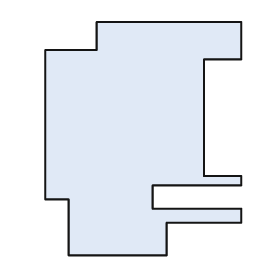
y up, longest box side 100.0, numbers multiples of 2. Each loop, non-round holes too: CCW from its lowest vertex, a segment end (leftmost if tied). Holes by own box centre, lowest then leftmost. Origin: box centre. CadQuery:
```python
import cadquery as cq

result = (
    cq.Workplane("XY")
    .moveTo(-32.0, -50.0)
    .lineTo(10.0, -50.0)
    .lineTo(10.0, -36.0)
    .lineTo(42.0, -36.0)
    .lineTo(42.0, -30.0)
    .lineTo(4.0, -30.0)
    .lineTo(4.0, -20.0)
    .lineTo(42.0, -20.0)
    .lineTo(42.0, -16.0)
    .lineTo(26.0, -16.0)
    .lineTo(26.0, 34.0)
    .lineTo(42.0, 34.0)
    .lineTo(42.0, 50.0)
    .lineTo(-20.0, 50.0)
    .lineTo(-20.0, 38.0)
    .lineTo(-42.0, 38.0)
    .lineTo(-42.0, -26.0)
    .lineTo(-32.0, -26.0)
    .close()
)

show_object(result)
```